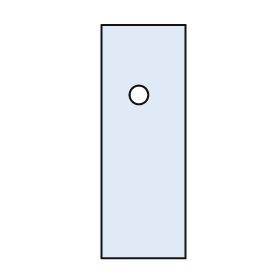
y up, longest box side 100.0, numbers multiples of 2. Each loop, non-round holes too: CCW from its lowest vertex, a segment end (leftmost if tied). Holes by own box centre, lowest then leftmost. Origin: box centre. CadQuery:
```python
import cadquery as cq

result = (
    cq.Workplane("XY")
    .moveTo(-18.0, -50.0)
    .lineTo(18.0, -50.0)
    .lineTo(18.0, 50.0)
    .lineTo(-18.0, 50.0)
    .close()
    .moveTo(-2.0, 20.0)
    .circle(4.0)
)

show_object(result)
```